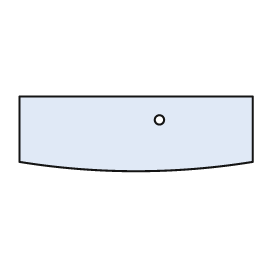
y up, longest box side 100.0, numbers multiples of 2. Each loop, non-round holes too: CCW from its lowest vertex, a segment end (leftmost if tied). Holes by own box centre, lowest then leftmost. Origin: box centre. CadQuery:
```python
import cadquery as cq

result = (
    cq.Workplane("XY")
    .moveTo(-50.0, -12.0)
    .threePointArc((0.0, -16.0), (50.0, -12.0))
    .lineTo(50.0, 16.0)
    .lineTo(-50.0, 16.0)
    .close()
    .moveTo(10.0, 6.0)
    .circle(2.0)
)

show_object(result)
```